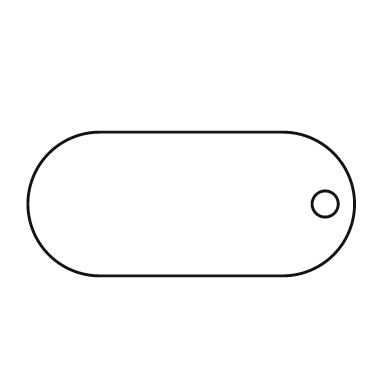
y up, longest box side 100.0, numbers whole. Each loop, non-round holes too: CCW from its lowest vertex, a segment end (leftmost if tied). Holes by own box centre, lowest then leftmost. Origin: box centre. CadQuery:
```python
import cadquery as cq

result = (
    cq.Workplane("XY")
    .moveTo(-28.0, -22.0)
    .lineTo(28.0, -22.0)
    .threePointArc((50.0, 0.0), (28.0, 22.0))
    .lineTo(-28.0, 22.0)
    .threePointArc((-50.0, 0.0), (-28.0, -22.0))
    .close()
    .moveTo(41.0, 0.0)
    .circle(4.0)
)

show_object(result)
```